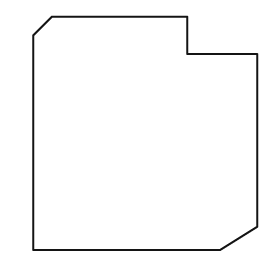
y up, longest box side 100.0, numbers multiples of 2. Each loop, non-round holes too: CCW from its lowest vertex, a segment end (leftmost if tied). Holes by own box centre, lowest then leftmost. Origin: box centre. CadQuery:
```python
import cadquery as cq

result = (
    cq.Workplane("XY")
    .moveTo(-48.0, -50.0)
    .lineTo(32.0, -50.0)
    .lineTo(48.0, -40.0)
    .lineTo(48.0, 34.0)
    .lineTo(18.0, 34.0)
    .lineTo(18.0, 50.0)
    .lineTo(-40.0, 50.0)
    .lineTo(-48.0, 42.0)
    .close()
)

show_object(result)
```